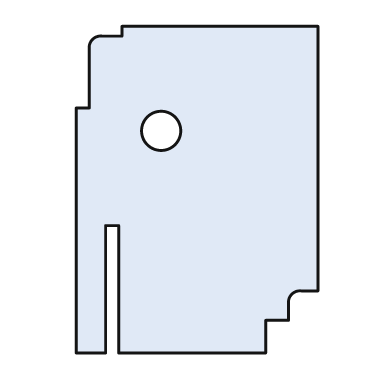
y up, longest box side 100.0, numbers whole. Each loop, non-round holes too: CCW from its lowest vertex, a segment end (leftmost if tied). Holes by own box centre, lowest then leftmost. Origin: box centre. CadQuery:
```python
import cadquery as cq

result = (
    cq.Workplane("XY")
    .moveTo(-37.0, -50.0)
    .lineTo(-28.0, -50.0)
    .lineTo(-28.0, -11.0)
    .lineTo(-24.0, -11.0)
    .lineTo(-24.0, -50.0)
    .lineTo(21.0, -50.0)
    .lineTo(21.0, -40.0)
    .lineTo(28.0, -40.0)
    .lineTo(28.0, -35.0)
    .threePointArc((29.0, -32.0), (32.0, -31.0))
    .lineTo(37.0, -31.0)
    .lineTo(37.0, 50.0)
    .lineTo(-23.0, 50.0)
    .lineTo(-23.0, 47.0)
    .lineTo(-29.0, 47.0)
    .threePointArc((-32.0, 46.0), (-33.0, 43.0))
    .lineTo(-33.0, 25.0)
    .lineTo(-37.0, 25.0)
    .close()
    .moveTo(-11.0, 18.0)
    .circle(6.0)
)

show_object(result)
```